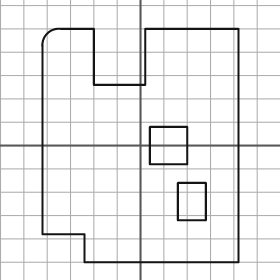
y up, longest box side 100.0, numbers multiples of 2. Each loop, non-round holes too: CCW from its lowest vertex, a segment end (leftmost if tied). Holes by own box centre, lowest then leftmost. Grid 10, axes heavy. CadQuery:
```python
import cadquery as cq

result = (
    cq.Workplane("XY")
    .moveTo(-24.0, -50.0)
    .lineTo(42.0, -50.0)
    .lineTo(42.0, 50.0)
    .lineTo(2.0, 50.0)
    .lineTo(2.0, 26.0)
    .lineTo(-20.0, 26.0)
    .lineTo(-20.0, 50.0)
    .lineTo(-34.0, 50.0)
    .threePointArc((-40.0, 48.0), (-42.0, 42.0))
    .lineTo(-42.0, -38.0)
    .lineTo(-24.0, -38.0)
    .close()
    .moveTo(16.0, -32.0)
    .lineTo(28.0, -32.0)
    .lineTo(28.0, -16.0)
    .lineTo(16.0, -16.0)
    .close()
    .moveTo(4.0, -8.0)
    .lineTo(20.0, -8.0)
    .lineTo(20.0, 8.0)
    .lineTo(4.0, 8.0)
    .close()
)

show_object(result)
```